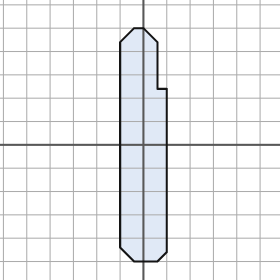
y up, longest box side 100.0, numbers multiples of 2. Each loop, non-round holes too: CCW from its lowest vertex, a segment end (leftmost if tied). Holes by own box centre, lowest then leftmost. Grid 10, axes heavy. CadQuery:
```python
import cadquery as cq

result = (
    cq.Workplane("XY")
    .moveTo(-4.0, -50.0)
    .lineTo(6.0, -50.0)
    .lineTo(10.0, -46.0)
    .lineTo(10.0, 24.0)
    .lineTo(6.0, 24.0)
    .lineTo(6.0, 44.0)
    .lineTo(0.0, 50.0)
    .lineTo(-4.0, 50.0)
    .lineTo(-10.0, 44.0)
    .lineTo(-10.0, -44.0)
    .close()
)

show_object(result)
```